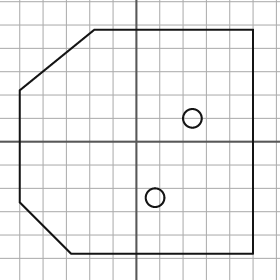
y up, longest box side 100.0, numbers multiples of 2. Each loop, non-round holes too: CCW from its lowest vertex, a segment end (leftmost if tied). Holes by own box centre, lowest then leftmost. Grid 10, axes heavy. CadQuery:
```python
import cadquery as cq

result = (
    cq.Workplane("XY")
    .moveTo(-28.0, -48.0)
    .lineTo(50.0, -48.0)
    .lineTo(50.0, 48.0)
    .lineTo(-18.0, 48.0)
    .lineTo(-50.0, 22.0)
    .lineTo(-50.0, -26.0)
    .close()
    .moveTo(8.0, -24.0)
    .circle(4.0)
    .moveTo(24.0, 10.0)
    .circle(4.0)
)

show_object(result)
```